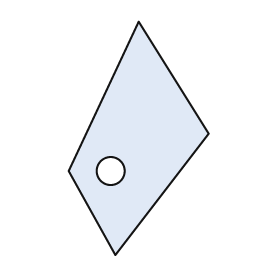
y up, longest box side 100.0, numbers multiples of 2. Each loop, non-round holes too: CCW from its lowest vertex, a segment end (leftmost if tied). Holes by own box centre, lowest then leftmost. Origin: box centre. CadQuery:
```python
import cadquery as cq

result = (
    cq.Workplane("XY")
    .moveTo(-10.0, -50.0)
    .lineTo(30.0, 2.0)
    .lineTo(0.0, 50.0)
    .lineTo(-30.0, -14.0)
    .close()
    .moveTo(-12.0, -14.0)
    .circle(6.0)
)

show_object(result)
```